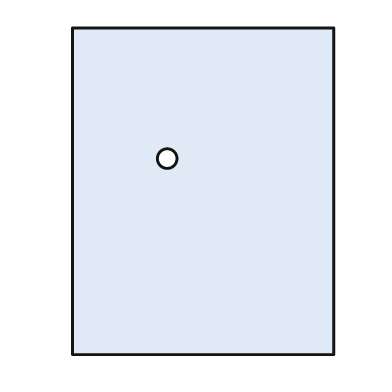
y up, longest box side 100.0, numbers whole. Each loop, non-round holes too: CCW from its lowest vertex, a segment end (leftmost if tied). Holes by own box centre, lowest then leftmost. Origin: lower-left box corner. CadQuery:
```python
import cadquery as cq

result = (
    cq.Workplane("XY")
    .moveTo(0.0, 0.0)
    .lineTo(80.0, 0.0)
    .lineTo(80.0, 100.0)
    .lineTo(0.0, 100.0)
    .close()
    .moveTo(29.0, 60.0)
    .circle(3.0)
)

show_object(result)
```